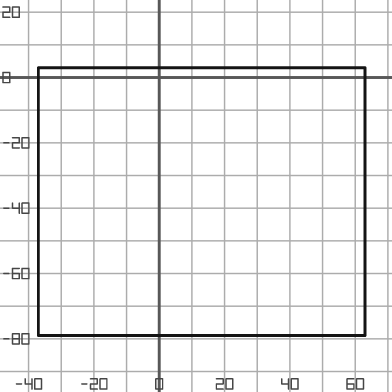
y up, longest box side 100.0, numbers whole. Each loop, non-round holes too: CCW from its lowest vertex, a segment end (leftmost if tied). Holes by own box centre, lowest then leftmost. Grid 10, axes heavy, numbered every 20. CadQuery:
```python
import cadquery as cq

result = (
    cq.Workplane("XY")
    .moveTo(-37.0, -79.0)
    .lineTo(63.0, -79.0)
    .lineTo(63.0, 3.0)
    .lineTo(-37.0, 3.0)
    .close()
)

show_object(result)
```